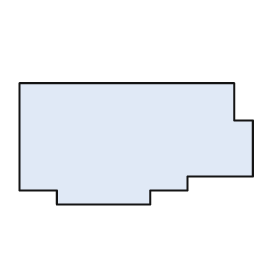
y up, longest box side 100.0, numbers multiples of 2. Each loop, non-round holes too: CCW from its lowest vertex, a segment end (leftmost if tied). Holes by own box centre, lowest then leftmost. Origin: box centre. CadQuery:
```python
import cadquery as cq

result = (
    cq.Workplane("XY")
    .moveTo(-34.0, -26.0)
    .lineTo(6.0, -26.0)
    .lineTo(6.0, -20.0)
    .lineTo(22.0, -20.0)
    .lineTo(22.0, -14.0)
    .lineTo(50.0, -14.0)
    .lineTo(50.0, 10.0)
    .lineTo(42.0, 10.0)
    .lineTo(42.0, 26.0)
    .lineTo(-50.0, 26.0)
    .lineTo(-50.0, -20.0)
    .lineTo(-34.0, -20.0)
    .close()
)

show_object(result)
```